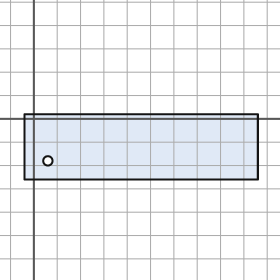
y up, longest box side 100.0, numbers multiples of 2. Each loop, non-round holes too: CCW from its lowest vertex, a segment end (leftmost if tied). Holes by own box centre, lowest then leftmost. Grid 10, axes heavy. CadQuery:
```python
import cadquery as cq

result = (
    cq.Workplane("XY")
    .moveTo(-4.0, -26.0)
    .lineTo(96.0, -26.0)
    .lineTo(96.0, 2.0)
    .lineTo(-4.0, 2.0)
    .close()
    .moveTo(6.0, -18.0)
    .circle(2.0)
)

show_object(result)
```